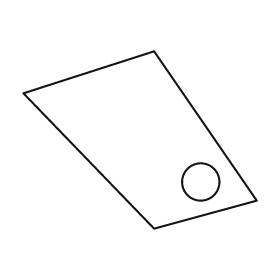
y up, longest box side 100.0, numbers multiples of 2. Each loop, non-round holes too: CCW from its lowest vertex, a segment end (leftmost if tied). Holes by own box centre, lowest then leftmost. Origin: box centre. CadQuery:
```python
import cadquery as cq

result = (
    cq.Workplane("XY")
    .moveTo(6.0, -38.0)
    .lineTo(50.0, -26.0)
    .lineTo(6.0, 38.0)
    .lineTo(-50.0, 20.0)
    .close()
    .moveTo(26.0, -18.0)
    .circle(8.0)
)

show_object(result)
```